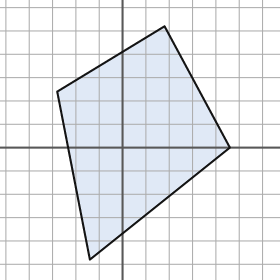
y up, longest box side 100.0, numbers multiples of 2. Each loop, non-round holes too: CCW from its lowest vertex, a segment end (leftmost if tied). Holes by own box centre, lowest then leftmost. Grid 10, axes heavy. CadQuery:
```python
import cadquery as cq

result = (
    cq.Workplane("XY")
    .moveTo(-14.0, -48.0)
    .lineTo(46.0, 0.0)
    .lineTo(18.0, 52.0)
    .lineTo(-28.0, 24.0)
    .close()
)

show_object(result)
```